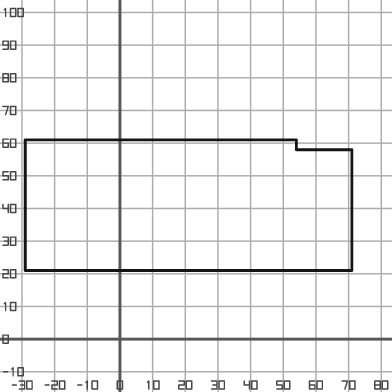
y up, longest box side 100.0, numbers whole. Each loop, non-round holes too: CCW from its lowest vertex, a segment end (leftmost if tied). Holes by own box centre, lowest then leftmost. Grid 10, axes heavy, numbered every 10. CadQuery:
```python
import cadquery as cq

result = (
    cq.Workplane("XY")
    .moveTo(-29.0, 21.0)
    .lineTo(71.0, 21.0)
    .lineTo(71.0, 58.0)
    .lineTo(54.0, 58.0)
    .lineTo(54.0, 61.0)
    .lineTo(-29.0, 61.0)
    .close()
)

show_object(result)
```